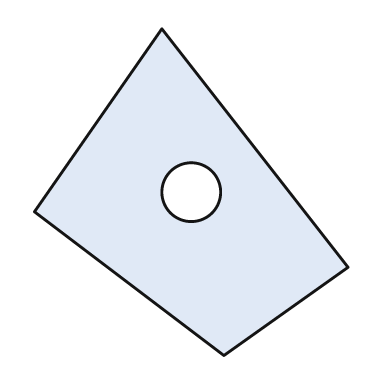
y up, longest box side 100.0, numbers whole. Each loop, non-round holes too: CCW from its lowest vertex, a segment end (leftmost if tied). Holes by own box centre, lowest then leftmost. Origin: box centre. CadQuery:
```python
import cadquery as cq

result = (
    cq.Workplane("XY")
    .moveTo(10.0, -50.0)
    .lineTo(48.0, -23.0)
    .lineTo(-9.0, 50.0)
    .lineTo(-48.0, -6.0)
    .close()
    .moveTo(0.0, 0.0)
    .circle(9.0)
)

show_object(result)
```